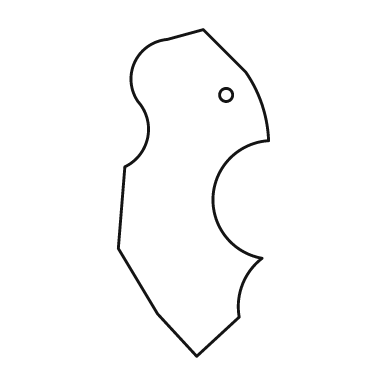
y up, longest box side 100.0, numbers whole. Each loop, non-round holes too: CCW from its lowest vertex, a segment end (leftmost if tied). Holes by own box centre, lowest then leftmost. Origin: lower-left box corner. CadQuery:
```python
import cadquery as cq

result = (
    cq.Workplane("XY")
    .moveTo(24.0, 0.0)
    .lineTo(37.0, 12.0)
    .threePointArc((38.0, 22.0), (44.0, 30.0))
    .threePointArc((29.0, 49.0), (46.0, 66.0))
    .threePointArc((44.0, 77.0), (39.0, 87.0))
    .lineTo(26.0, 100.0)
    .lineTo(15.0, 97.0)
    .threePointArc((5.0, 90.0), (6.0, 78.0))
    .threePointArc((9.0, 67.0), (2.0, 58.0))
    .lineTo(0.0, 33.0)
    .lineTo(12.0, 13.0)
    .close()
    .moveTo(33.0, 80.0)
    .circle(2.0)
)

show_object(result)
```